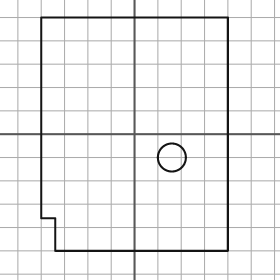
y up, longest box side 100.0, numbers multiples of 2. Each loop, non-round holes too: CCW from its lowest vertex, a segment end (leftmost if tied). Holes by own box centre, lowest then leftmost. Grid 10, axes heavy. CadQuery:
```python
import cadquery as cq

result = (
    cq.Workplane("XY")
    .moveTo(-34.0, -50.0)
    .lineTo(40.0, -50.0)
    .lineTo(40.0, 50.0)
    .lineTo(-40.0, 50.0)
    .lineTo(-40.0, -36.0)
    .lineTo(-34.0, -36.0)
    .close()
    .moveTo(16.0, -10.0)
    .circle(6.0)
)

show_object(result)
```